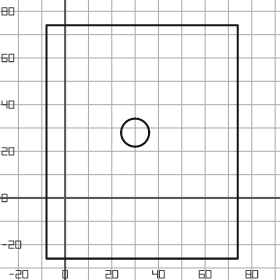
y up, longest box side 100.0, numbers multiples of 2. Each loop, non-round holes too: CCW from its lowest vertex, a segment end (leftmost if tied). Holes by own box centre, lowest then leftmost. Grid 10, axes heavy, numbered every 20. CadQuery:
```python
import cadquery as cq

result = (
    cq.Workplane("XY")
    .moveTo(-8.0, -26.0)
    .lineTo(74.0, -26.0)
    .lineTo(74.0, 74.0)
    .lineTo(-8.0, 74.0)
    .close()
    .moveTo(30.0, 28.0)
    .circle(6.0)
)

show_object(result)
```